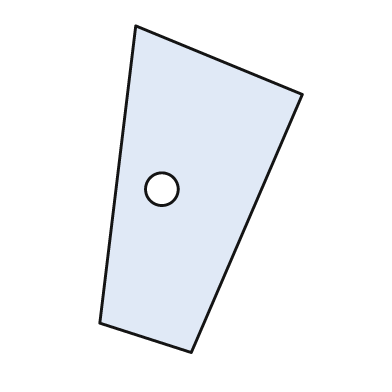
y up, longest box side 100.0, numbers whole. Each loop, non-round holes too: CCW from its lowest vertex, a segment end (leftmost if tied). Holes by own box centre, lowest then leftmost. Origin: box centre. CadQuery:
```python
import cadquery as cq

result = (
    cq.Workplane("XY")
    .moveTo(-3.0, -50.0)
    .lineTo(31.0, 29.0)
    .lineTo(-20.0, 50.0)
    .lineTo(-31.0, -41.0)
    .close()
    .moveTo(-12.0, 0.0)
    .circle(5.0)
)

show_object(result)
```